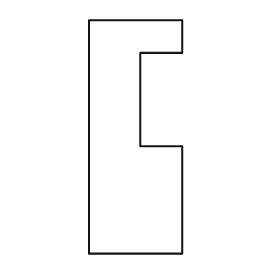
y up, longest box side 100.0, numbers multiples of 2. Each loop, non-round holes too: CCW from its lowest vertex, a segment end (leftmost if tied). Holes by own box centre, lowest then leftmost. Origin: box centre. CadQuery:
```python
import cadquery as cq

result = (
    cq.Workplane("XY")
    .moveTo(-20.0, -50.0)
    .lineTo(20.0, -50.0)
    .lineTo(20.0, -4.0)
    .lineTo(2.0, -4.0)
    .lineTo(2.0, 36.0)
    .lineTo(20.0, 36.0)
    .lineTo(20.0, 50.0)
    .lineTo(-20.0, 50.0)
    .close()
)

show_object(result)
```